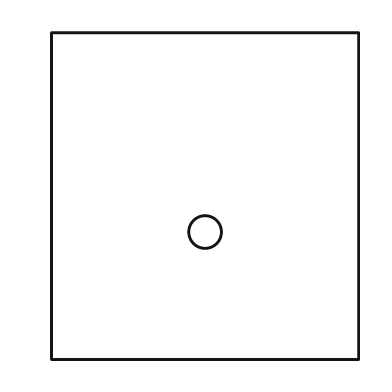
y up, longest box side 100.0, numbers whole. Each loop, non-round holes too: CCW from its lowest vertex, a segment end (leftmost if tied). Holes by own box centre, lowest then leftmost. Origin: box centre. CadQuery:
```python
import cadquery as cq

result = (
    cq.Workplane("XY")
    .moveTo(-47.0, -50.0)
    .lineTo(47.0, -50.0)
    .lineTo(47.0, 50.0)
    .lineTo(-47.0, 50.0)
    .close()
    .moveTo(0.0, -11.0)
    .circle(5.0)
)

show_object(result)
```